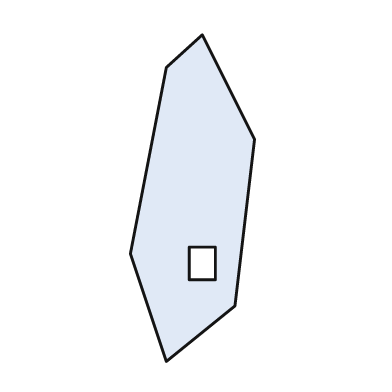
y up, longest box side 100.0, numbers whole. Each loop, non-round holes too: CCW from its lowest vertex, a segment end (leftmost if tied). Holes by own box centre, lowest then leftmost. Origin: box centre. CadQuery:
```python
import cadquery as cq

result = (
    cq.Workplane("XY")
    .moveTo(-8.0, -50.0)
    .lineTo(13.0, -33.0)
    .lineTo(19.0, 18.0)
    .lineTo(3.0, 50.0)
    .lineTo(-8.0, 40.0)
    .lineTo(-19.0, -17.0)
    .close()
    .moveTo(-1.0, -25.0)
    .lineTo(7.0, -25.0)
    .lineTo(7.0, -15.0)
    .lineTo(-1.0, -15.0)
    .close()
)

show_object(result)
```